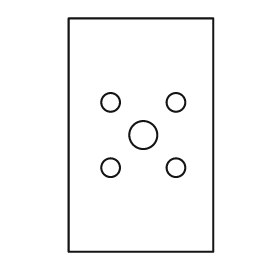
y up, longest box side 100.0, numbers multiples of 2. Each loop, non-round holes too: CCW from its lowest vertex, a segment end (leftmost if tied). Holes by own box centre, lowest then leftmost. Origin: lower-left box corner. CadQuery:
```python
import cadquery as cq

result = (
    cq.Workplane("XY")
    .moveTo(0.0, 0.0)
    .lineTo(62.0, 0.0)
    .lineTo(62.0, 100.0)
    .lineTo(0.0, 100.0)
    .close()
    .moveTo(18.0, 36.0)
    .circle(4.0)
    .moveTo(46.0, 36.0)
    .circle(4.0)
    .moveTo(32.0, 50.0)
    .circle(6.0)
    .moveTo(18.0, 64.0)
    .circle(4.0)
    .moveTo(46.0, 64.0)
    .circle(4.0)
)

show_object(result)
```